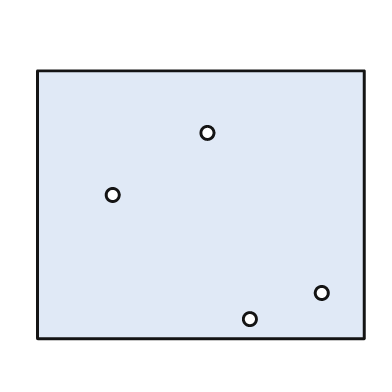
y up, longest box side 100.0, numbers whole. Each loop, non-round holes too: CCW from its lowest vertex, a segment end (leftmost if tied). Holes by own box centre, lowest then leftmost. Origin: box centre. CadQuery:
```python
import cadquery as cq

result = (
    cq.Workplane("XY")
    .moveTo(-50.0, -41.0)
    .lineTo(50.0, -41.0)
    .lineTo(50.0, 41.0)
    .lineTo(-50.0, 41.0)
    .close()
    .moveTo(15.0, -35.0)
    .circle(2.0)
    .moveTo(37.0, -27.0)
    .circle(2.0)
    .moveTo(-27.0, 3.0)
    .circle(2.0)
    .moveTo(2.0, 22.0)
    .circle(2.0)
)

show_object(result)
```